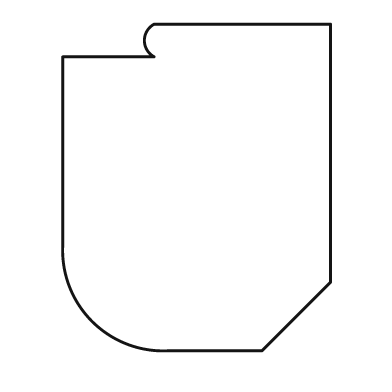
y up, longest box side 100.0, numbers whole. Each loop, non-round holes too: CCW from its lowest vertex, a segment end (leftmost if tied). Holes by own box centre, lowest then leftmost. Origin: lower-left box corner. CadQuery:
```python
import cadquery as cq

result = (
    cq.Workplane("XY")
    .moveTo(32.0, 0.0)
    .lineTo(61.0, 0.0)
    .lineTo(82.0, 21.0)
    .lineTo(82.0, 100.0)
    .lineTo(28.0, 100.0)
    .threePointArc((25.0, 95.0), (28.0, 90.0))
    .lineTo(0.0, 90.0)
    .lineTo(0.0, 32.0)
    .threePointArc((9.0, 9.0), (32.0, 0.0))
    .close()
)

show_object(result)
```